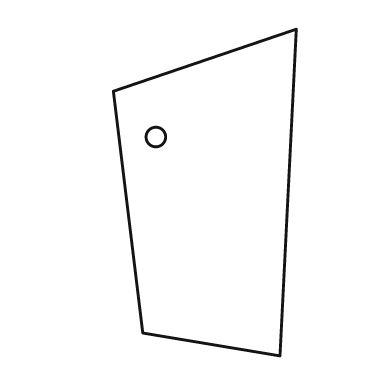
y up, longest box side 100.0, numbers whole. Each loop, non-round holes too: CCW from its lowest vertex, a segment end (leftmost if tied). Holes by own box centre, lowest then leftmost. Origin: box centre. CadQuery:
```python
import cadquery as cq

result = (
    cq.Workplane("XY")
    .moveTo(23.0, -50.0)
    .lineTo(28.0, 50.0)
    .lineTo(-28.0, 31.0)
    .lineTo(-19.0, -43.0)
    .close()
    .moveTo(-15.0, 17.0)
    .circle(3.0)
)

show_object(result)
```